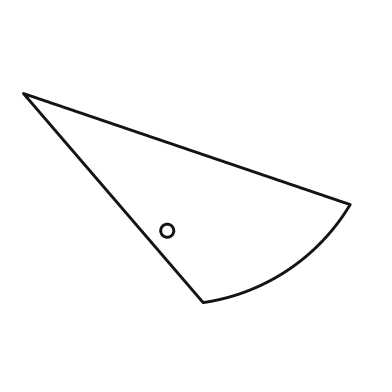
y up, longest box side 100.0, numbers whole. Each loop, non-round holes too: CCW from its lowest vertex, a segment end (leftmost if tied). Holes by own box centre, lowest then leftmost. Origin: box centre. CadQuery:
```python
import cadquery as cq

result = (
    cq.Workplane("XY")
    .moveTo(5.0, -32.0)
    .threePointArc((31.0, -22.0), (50.0, -2.0))
    .lineTo(-50.0, 32.0)
    .close()
    .moveTo(-6.0, -10.0)
    .circle(2.0)
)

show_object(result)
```